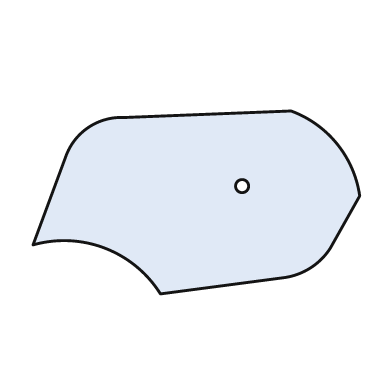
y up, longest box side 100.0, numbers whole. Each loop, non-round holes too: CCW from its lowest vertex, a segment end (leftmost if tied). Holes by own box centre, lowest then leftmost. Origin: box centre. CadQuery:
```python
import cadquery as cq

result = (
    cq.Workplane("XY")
    .moveTo(-11.0, -28.0)
    .lineTo(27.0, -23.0)
    .threePointArc((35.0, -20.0), (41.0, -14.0))
    .lineTo(50.0, 2.0)
    .threePointArc((43.0, 18.0), (29.0, 28.0))
    .lineTo(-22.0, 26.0)
    .threePointArc((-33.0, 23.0), (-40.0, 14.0))
    .lineTo(-50.0, -13.0)
    .threePointArc((-28.0, -14.0), (-11.0, -28.0))
    .close()
    .moveTo(14.0, 5.0)
    .circle(2.0)
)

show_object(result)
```